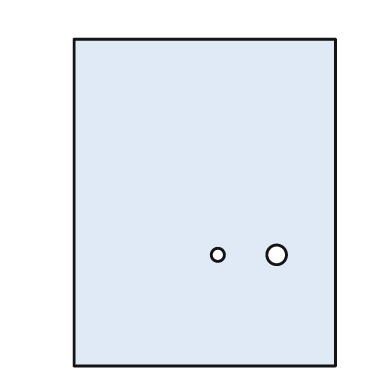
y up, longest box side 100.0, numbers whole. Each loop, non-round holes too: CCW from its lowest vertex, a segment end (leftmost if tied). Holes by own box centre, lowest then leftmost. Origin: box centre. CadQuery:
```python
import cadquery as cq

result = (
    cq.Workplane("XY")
    .moveTo(-40.0, -50.0)
    .lineTo(40.0, -50.0)
    .lineTo(40.0, 50.0)
    .lineTo(-40.0, 50.0)
    .close()
    .moveTo(4.0, -16.0)
    .circle(2.0)
    .moveTo(22.0, -16.0)
    .circle(3.0)
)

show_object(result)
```